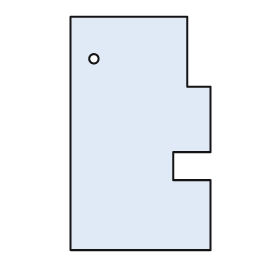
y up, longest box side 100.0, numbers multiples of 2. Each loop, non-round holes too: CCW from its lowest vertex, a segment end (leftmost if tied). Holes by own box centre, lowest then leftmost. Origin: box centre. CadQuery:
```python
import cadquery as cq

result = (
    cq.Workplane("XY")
    .moveTo(-30.0, -50.0)
    .lineTo(30.0, -50.0)
    .lineTo(30.0, -20.0)
    .lineTo(14.0, -20.0)
    .lineTo(14.0, -8.0)
    .lineTo(30.0, -8.0)
    .lineTo(30.0, 20.0)
    .lineTo(20.0, 20.0)
    .lineTo(20.0, 50.0)
    .lineTo(-30.0, 50.0)
    .close()
    .moveTo(-20.0, 32.0)
    .circle(2.0)
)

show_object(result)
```